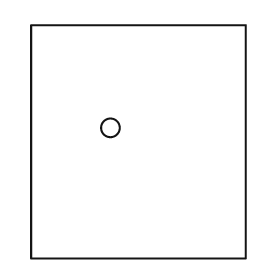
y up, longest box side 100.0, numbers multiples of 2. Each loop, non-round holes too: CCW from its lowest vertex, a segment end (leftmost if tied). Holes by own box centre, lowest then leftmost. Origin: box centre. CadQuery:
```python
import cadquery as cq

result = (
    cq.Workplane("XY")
    .moveTo(-46.0, -50.0)
    .lineTo(46.0, -50.0)
    .lineTo(46.0, 50.0)
    .lineTo(-46.0, 50.0)
    .close()
    .moveTo(-12.0, 6.0)
    .circle(4.0)
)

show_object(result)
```